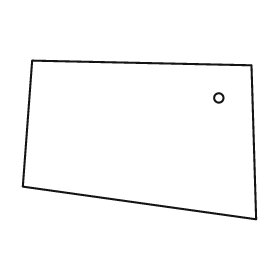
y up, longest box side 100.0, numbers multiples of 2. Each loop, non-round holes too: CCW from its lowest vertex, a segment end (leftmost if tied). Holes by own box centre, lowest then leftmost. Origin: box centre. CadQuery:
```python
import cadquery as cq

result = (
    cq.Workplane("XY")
    .moveTo(50.0, -34.0)
    .lineTo(48.0, 32.0)
    .lineTo(-46.0, 34.0)
    .lineTo(-50.0, -20.0)
    .close()
    .moveTo(34.0, 18.0)
    .circle(2.0)
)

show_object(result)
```